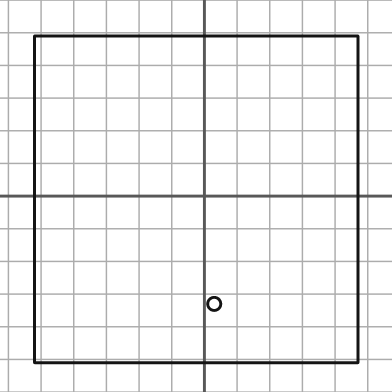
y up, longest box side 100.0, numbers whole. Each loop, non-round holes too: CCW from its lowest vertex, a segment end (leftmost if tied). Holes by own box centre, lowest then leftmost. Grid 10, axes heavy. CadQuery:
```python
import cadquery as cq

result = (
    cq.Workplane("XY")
    .moveTo(-52.0, -51.0)
    .lineTo(47.0, -51.0)
    .lineTo(47.0, 49.0)
    .lineTo(-52.0, 49.0)
    .close()
    .moveTo(3.0, -33.0)
    .circle(2.0)
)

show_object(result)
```